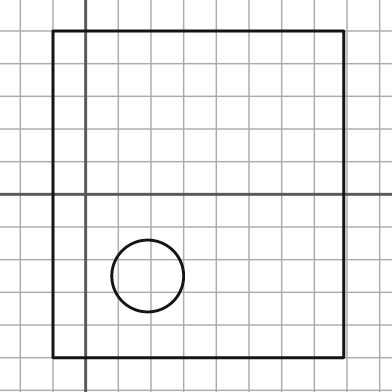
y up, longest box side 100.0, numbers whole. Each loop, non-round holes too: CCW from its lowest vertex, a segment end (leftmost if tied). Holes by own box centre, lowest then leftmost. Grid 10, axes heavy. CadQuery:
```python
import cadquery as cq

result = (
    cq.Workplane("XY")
    .moveTo(-10.0, -50.0)
    .lineTo(79.0, -50.0)
    .lineTo(79.0, 50.0)
    .lineTo(-10.0, 50.0)
    .close()
    .moveTo(19.0, -25.0)
    .circle(11.0)
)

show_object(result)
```